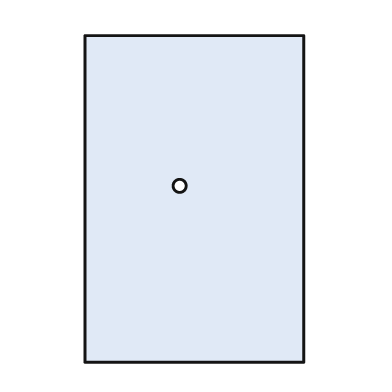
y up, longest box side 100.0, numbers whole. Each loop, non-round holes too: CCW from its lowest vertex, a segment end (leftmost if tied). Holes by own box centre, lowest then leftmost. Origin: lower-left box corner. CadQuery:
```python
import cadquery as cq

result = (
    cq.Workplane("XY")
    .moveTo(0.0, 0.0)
    .lineTo(67.0, 0.0)
    .lineTo(67.0, 100.0)
    .lineTo(0.0, 100.0)
    .close()
    .moveTo(29.0, 54.0)
    .circle(2.0)
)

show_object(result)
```